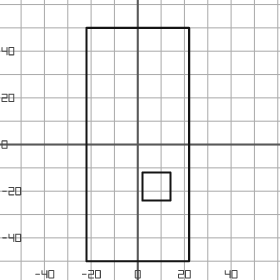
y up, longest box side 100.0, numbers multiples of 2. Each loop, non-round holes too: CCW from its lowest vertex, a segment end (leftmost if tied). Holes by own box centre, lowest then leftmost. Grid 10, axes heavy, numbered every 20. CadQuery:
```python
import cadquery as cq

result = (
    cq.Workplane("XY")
    .moveTo(-22.0, -50.0)
    .lineTo(22.0, -50.0)
    .lineTo(22.0, 50.0)
    .lineTo(-22.0, 50.0)
    .close()
    .moveTo(2.0, -24.0)
    .lineTo(14.0, -24.0)
    .lineTo(14.0, -12.0)
    .lineTo(2.0, -12.0)
    .close()
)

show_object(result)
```